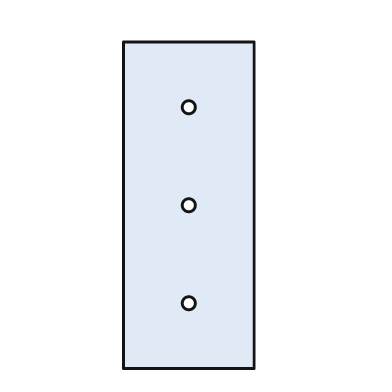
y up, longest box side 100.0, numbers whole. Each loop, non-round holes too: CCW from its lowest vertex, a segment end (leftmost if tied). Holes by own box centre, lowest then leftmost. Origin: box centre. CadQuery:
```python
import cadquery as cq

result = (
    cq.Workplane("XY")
    .moveTo(-20.0, -50.0)
    .lineTo(20.0, -50.0)
    .lineTo(20.0, 50.0)
    .lineTo(-20.0, 50.0)
    .close()
    .moveTo(0.0, -30.0)
    .circle(2.0)
    .moveTo(0.0, 0.0)
    .circle(2.0)
    .moveTo(0.0, 30.0)
    .circle(2.0)
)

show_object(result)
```